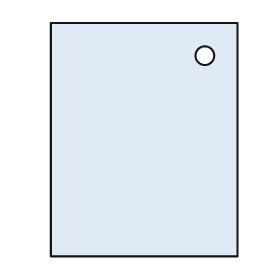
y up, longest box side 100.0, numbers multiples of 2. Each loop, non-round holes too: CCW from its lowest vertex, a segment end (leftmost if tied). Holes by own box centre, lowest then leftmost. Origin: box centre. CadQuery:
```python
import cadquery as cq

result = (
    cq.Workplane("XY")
    .moveTo(-40.0, -50.0)
    .lineTo(40.0, -50.0)
    .lineTo(40.0, 50.0)
    .lineTo(-40.0, 50.0)
    .close()
    .moveTo(26.0, 36.0)
    .circle(4.0)
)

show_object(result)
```